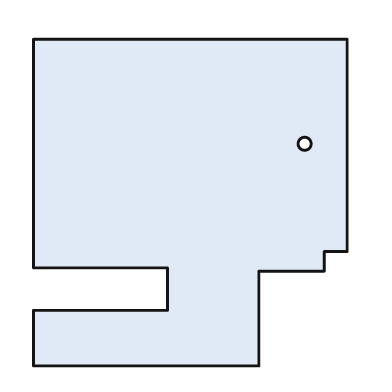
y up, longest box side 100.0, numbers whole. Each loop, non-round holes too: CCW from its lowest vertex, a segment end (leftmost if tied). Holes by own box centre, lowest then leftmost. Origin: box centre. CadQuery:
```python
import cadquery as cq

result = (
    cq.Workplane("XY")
    .moveTo(-48.0, -50.0)
    .lineTo(21.0, -50.0)
    .lineTo(21.0, -21.0)
    .lineTo(41.0, -21.0)
    .lineTo(41.0, -15.0)
    .lineTo(48.0, -15.0)
    .lineTo(48.0, 50.0)
    .lineTo(-48.0, 50.0)
    .lineTo(-48.0, -20.0)
    .lineTo(-7.0, -20.0)
    .lineTo(-7.0, -33.0)
    .lineTo(-48.0, -33.0)
    .close()
    .moveTo(35.0, 18.0)
    .circle(2.0)
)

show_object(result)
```